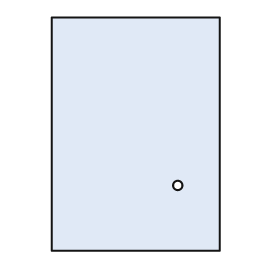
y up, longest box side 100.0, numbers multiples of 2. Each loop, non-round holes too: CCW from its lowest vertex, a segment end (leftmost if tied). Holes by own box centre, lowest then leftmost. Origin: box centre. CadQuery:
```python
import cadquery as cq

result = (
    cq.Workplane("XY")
    .moveTo(-36.0, -50.0)
    .lineTo(36.0, -50.0)
    .lineTo(36.0, 50.0)
    .lineTo(-36.0, 50.0)
    .close()
    .moveTo(18.0, -22.0)
    .circle(2.0)
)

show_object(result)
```